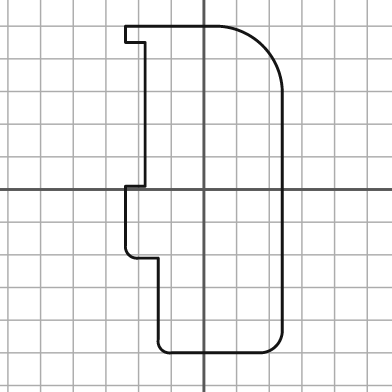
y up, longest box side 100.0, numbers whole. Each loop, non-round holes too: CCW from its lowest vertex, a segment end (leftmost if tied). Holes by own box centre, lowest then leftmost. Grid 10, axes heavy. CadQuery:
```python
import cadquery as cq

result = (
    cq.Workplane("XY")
    .moveTo(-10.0, -50.0)
    .lineTo(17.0, -50.0)
    .threePointArc((22.0, -48.0), (24.0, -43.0))
    .lineTo(24.0, 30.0)
    .threePointArc((18.0, 44.0), (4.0, 50.0))
    .lineTo(-24.0, 50.0)
    .lineTo(-24.0, 45.0)
    .lineTo(-18.0, 45.0)
    .lineTo(-18.0, 1.0)
    .lineTo(-24.0, 1.0)
    .lineTo(-24.0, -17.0)
    .threePointArc((-23.0, -20.0), (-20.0, -21.0))
    .lineTo(-14.0, -21.0)
    .lineTo(-14.0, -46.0)
    .threePointArc((-13.0, -49.0), (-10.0, -50.0))
    .close()
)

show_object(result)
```